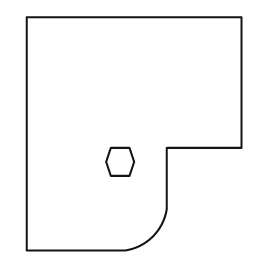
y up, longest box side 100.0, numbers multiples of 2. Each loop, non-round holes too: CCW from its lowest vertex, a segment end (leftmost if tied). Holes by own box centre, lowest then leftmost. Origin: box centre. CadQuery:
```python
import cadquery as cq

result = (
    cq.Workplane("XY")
    .moveTo(-46.0, -50.0)
    .lineTo(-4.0, -50.0)
    .threePointArc((8.0, -44.0), (14.0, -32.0))
    .lineTo(14.0, -6.0)
    .lineTo(46.0, -6.0)
    .lineTo(46.0, 50.0)
    .lineTo(-46.0, 50.0)
    .close()
    .moveTo(-10.0, -18.0)
    .lineTo(-2.0, -18.0)
    .lineTo(0.0, -12.0)
    .lineTo(-2.0, -6.0)
    .lineTo(-10.0, -6.0)
    .lineTo(-12.0, -12.0)
    .close()
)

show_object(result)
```